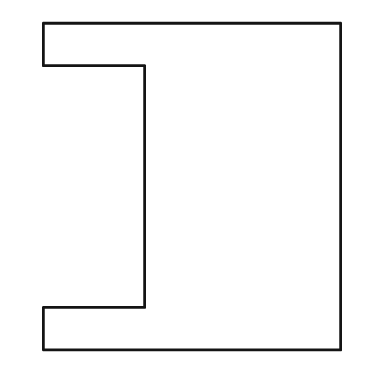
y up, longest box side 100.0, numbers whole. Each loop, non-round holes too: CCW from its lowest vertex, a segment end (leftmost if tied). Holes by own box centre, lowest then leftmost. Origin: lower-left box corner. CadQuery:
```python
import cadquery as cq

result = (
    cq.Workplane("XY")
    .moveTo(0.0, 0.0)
    .lineTo(91.0, 0.0)
    .lineTo(91.0, 100.0)
    .lineTo(0.0, 100.0)
    .lineTo(0.0, 87.0)
    .lineTo(31.0, 87.0)
    .lineTo(31.0, 13.0)
    .lineTo(0.0, 13.0)
    .close()
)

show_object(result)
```